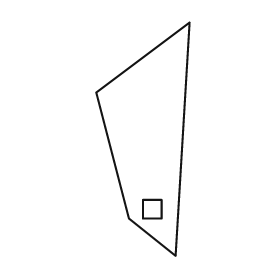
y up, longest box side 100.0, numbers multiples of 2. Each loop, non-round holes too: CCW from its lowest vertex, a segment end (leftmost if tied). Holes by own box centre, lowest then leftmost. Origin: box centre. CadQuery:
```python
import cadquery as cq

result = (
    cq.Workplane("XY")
    .moveTo(14.0, -50.0)
    .lineTo(20.0, 50.0)
    .lineTo(-20.0, 20.0)
    .lineTo(-6.0, -34.0)
    .close()
    .moveTo(0.0, -34.0)
    .lineTo(8.0, -34.0)
    .lineTo(8.0, -26.0)
    .lineTo(0.0, -26.0)
    .close()
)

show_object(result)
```